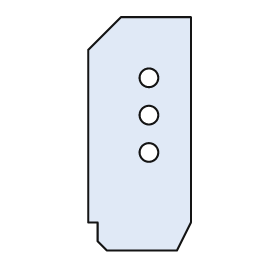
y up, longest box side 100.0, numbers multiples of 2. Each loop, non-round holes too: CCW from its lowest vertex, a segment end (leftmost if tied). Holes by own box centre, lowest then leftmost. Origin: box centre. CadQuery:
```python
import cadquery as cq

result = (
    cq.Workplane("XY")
    .moveTo(-14.0, -50.0)
    .lineTo(16.0, -50.0)
    .lineTo(22.0, -38.0)
    .lineTo(22.0, 50.0)
    .lineTo(-8.0, 50.0)
    .lineTo(-22.0, 36.0)
    .lineTo(-22.0, -38.0)
    .lineTo(-18.0, -38.0)
    .lineTo(-18.0, -46.0)
    .close()
    .moveTo(4.0, -8.0)
    .circle(4.0)
    .moveTo(4.0, 8.0)
    .circle(4.0)
    .moveTo(4.0, 24.0)
    .circle(4.0)
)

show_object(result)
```